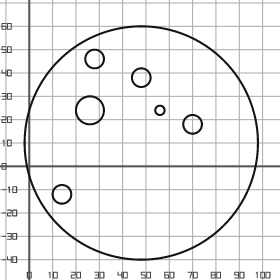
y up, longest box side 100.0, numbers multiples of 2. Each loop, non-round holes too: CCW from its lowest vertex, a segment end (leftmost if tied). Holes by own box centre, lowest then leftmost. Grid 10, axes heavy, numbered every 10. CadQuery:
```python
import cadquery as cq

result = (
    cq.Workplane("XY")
    .moveTo(48.0, 10.0)
    .circle(50.0)
    .moveTo(14.0, -12.0)
    .circle(4.0)
    .moveTo(70.0, 18.0)
    .circle(4.0)
    .moveTo(26.0, 24.0)
    .circle(6.0)
    .moveTo(56.0, 24.0)
    .circle(2.0)
    .moveTo(48.0, 38.0)
    .circle(4.0)
    .moveTo(28.0, 46.0)
    .circle(4.0)
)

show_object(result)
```